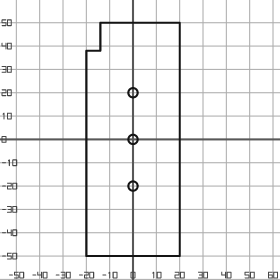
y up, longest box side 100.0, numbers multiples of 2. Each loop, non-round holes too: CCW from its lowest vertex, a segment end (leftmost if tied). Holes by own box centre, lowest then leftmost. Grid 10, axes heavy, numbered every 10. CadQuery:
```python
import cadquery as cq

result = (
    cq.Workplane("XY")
    .moveTo(-20.0, -50.0)
    .lineTo(20.0, -50.0)
    .lineTo(20.0, 50.0)
    .lineTo(-14.0, 50.0)
    .lineTo(-14.0, 38.0)
    .lineTo(-20.0, 38.0)
    .close()
    .moveTo(0.0, -20.0)
    .circle(2.0)
    .moveTo(0.0, 0.0)
    .circle(2.0)
    .moveTo(0.0, 20.0)
    .circle(2.0)
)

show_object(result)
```